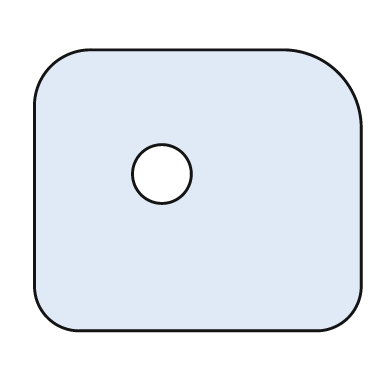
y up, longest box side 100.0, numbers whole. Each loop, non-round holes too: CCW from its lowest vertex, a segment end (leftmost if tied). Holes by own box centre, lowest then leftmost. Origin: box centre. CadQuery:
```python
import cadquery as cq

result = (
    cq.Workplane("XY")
    .moveTo(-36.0, -43.0)
    .lineTo(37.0, -43.0)
    .threePointArc((46.0, -39.0), (50.0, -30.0))
    .lineTo(50.0, 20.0)
    .threePointArc((43.0, 36.0), (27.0, 43.0))
    .lineTo(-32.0, 43.0)
    .threePointArc((-45.0, 38.0), (-50.0, 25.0))
    .lineTo(-50.0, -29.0)
    .threePointArc((-46.0, -39.0), (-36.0, -43.0))
    .close()
    .moveTo(-11.0, 5.0)
    .circle(9.0)
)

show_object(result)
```